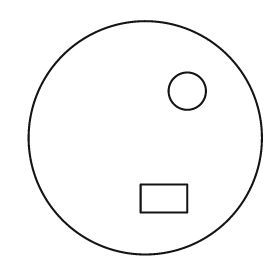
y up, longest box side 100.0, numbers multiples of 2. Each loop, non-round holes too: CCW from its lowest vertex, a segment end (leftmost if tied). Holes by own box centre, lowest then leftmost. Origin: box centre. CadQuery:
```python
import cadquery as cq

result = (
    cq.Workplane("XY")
    .moveTo(0.0, 0.0)
    .circle(50.0)
    .moveTo(-2.0, -32.0)
    .lineTo(18.0, -32.0)
    .lineTo(18.0, -20.0)
    .lineTo(-2.0, -20.0)
    .close()
    .moveTo(18.0, 20.0)
    .circle(8.0)
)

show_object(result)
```